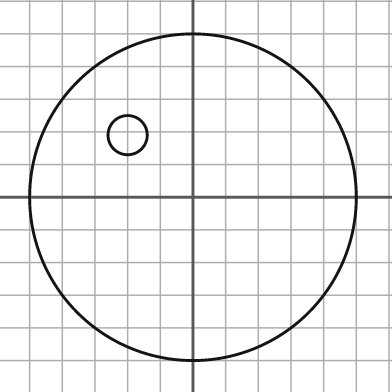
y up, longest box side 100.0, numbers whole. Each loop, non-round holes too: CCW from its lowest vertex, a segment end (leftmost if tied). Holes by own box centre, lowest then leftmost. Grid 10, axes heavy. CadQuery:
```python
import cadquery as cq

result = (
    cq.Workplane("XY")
    .moveTo(0.0, 0.0)
    .circle(50.0)
    .moveTo(-20.0, 19.0)
    .circle(6.0)
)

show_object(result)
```